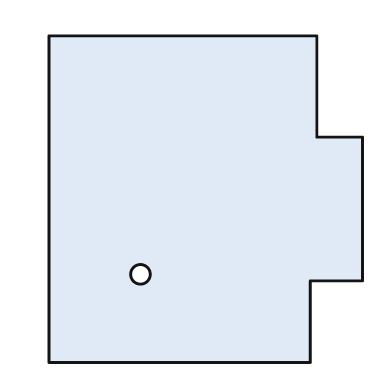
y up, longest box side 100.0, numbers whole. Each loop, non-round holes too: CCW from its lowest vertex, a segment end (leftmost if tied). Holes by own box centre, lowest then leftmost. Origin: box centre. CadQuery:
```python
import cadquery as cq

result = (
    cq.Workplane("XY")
    .moveTo(-48.0, -50.0)
    .lineTo(32.0, -50.0)
    .lineTo(32.0, -25.0)
    .lineTo(48.0, -25.0)
    .lineTo(48.0, 19.0)
    .lineTo(34.0, 19.0)
    .lineTo(34.0, 50.0)
    .lineTo(-48.0, 50.0)
    .close()
    .moveTo(-20.0, -23.0)
    .circle(3.0)
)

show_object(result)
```